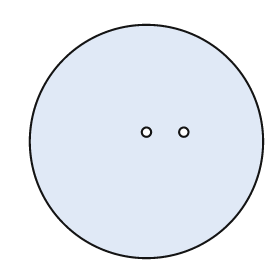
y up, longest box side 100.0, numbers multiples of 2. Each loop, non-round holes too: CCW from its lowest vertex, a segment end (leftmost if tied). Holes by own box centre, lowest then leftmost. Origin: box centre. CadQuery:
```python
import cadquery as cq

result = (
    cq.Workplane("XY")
    .moveTo(0.0, 0.0)
    .circle(50.0)
    .moveTo(0.0, 4.0)
    .circle(2.0)
    .moveTo(16.0, 4.0)
    .circle(2.0)
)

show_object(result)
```